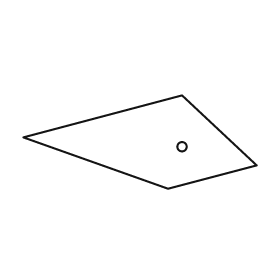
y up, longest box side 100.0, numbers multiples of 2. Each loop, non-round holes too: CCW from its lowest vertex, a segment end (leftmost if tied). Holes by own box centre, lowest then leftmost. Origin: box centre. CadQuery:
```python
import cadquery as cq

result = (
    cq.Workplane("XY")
    .moveTo(12.0, -20.0)
    .lineTo(50.0, -10.0)
    .lineTo(18.0, 20.0)
    .lineTo(-50.0, 2.0)
    .close()
    .moveTo(18.0, -2.0)
    .circle(2.0)
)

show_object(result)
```